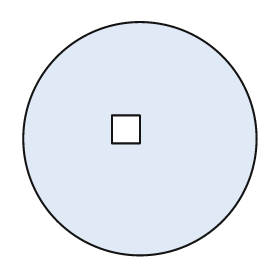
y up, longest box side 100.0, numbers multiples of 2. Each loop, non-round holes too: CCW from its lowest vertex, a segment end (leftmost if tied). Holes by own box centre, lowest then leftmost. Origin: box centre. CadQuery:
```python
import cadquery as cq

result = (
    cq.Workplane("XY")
    .moveTo(0.0, 0.0)
    .circle(50.0)
    .moveTo(-12.0, -2.0)
    .lineTo(0.0, -2.0)
    .lineTo(0.0, 10.0)
    .lineTo(-12.0, 10.0)
    .close()
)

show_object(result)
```